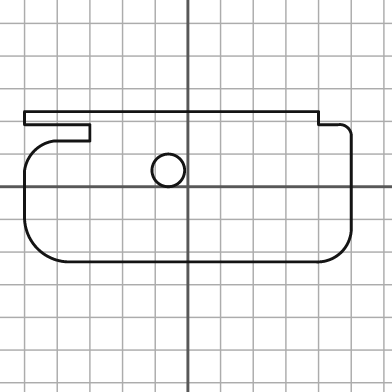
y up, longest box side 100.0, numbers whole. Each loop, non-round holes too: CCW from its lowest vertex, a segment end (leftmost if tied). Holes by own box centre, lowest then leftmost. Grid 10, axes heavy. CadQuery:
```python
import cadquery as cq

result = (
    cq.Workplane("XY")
    .moveTo(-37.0, -23.0)
    .lineTo(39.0, -23.0)
    .threePointArc((47.0, -20.0), (50.0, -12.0))
    .lineTo(50.0, 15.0)
    .threePointArc((49.0, 18.0), (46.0, 19.0))
    .lineTo(40.0, 19.0)
    .lineTo(40.0, 23.0)
    .lineTo(-50.0, 23.0)
    .lineTo(-50.0, 19.0)
    .lineTo(-30.0, 19.0)
    .lineTo(-30.0, 14.0)
    .lineTo(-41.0, 14.0)
    .threePointArc((-47.0, 11.0), (-50.0, 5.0))
    .lineTo(-50.0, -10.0)
    .threePointArc((-46.0, -19.0), (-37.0, -23.0))
    .close()
    .moveTo(-6.0, 5.0)
    .circle(5.0)
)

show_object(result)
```